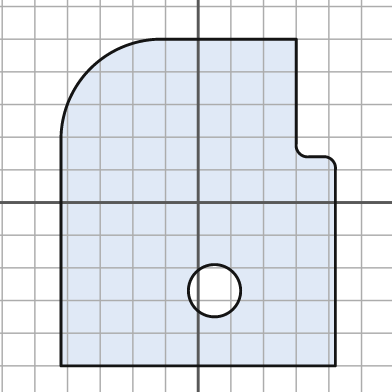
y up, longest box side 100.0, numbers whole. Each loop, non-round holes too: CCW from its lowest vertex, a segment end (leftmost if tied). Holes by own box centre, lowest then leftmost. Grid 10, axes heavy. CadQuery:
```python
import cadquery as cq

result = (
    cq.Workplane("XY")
    .moveTo(-42.0, -50.0)
    .lineTo(42.0, -50.0)
    .lineTo(42.0, 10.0)
    .threePointArc((41.0, 13.0), (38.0, 14.0))
    .lineTo(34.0, 14.0)
    .threePointArc((31.0, 15.0), (30.0, 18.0))
    .lineTo(30.0, 50.0)
    .lineTo(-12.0, 50.0)
    .threePointArc((-33.0, 41.0), (-42.0, 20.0))
    .close()
    .moveTo(5.0, -27.0)
    .circle(8.0)
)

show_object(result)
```